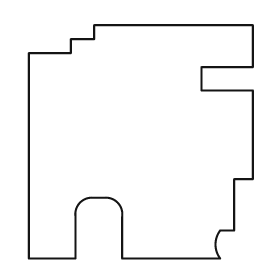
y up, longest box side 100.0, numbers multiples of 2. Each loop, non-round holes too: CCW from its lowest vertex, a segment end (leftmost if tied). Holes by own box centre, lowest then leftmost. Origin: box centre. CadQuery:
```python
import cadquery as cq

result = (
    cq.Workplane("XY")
    .moveTo(-48.0, -50.0)
    .lineTo(-28.0, -50.0)
    .lineTo(-28.0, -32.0)
    .threePointArc((-26.0, -26.0), (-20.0, -24.0))
    .lineTo(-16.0, -24.0)
    .threePointArc((-10.0, -26.0), (-8.0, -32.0))
    .lineTo(-8.0, -50.0)
    .lineTo(34.0, -50.0)
    .threePointArc((32.0, -44.0), (34.0, -38.0))
    .lineTo(40.0, -38.0)
    .lineTo(40.0, -16.0)
    .lineTo(48.0, -16.0)
    .lineTo(48.0, 22.0)
    .lineTo(26.0, 22.0)
    .lineTo(26.0, 32.0)
    .lineTo(48.0, 32.0)
    .lineTo(48.0, 50.0)
    .lineTo(-20.0, 50.0)
    .lineTo(-20.0, 44.0)
    .lineTo(-30.0, 44.0)
    .lineTo(-30.0, 38.0)
    .lineTo(-48.0, 38.0)
    .close()
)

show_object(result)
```